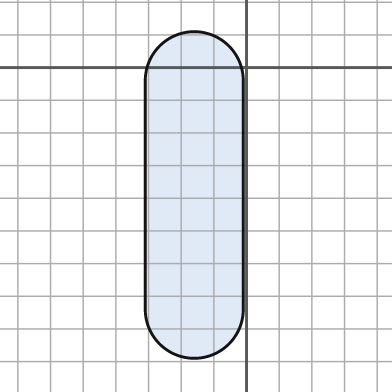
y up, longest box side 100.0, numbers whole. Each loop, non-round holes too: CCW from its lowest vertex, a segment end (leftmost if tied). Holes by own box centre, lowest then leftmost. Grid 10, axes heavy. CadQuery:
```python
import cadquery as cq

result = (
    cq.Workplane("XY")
    .moveTo(-31.0, -74.0)
    .threePointArc((-16.0, -89.0), (-1.0, -74.0))
    .lineTo(-1.0, -4.0)
    .threePointArc((-16.0, 11.0), (-31.0, -4.0))
    .close()
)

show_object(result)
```